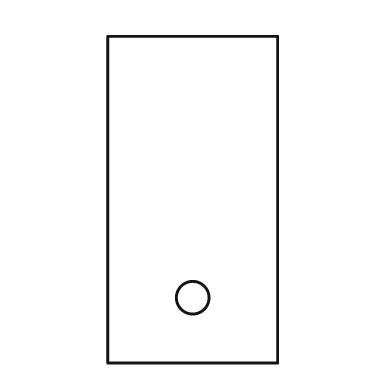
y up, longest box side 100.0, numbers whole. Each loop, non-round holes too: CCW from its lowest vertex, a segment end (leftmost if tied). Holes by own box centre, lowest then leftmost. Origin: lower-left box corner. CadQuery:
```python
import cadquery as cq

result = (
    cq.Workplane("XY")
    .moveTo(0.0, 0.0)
    .lineTo(52.0, 0.0)
    .lineTo(52.0, 100.0)
    .lineTo(0.0, 100.0)
    .close()
    .moveTo(26.0, 20.0)
    .circle(5.0)
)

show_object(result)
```